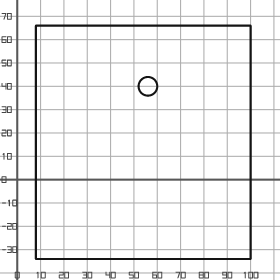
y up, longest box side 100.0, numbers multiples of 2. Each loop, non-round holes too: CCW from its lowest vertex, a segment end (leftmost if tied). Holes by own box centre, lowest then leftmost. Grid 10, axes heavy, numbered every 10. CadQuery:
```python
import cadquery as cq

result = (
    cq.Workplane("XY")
    .moveTo(8.0, -34.0)
    .lineTo(100.0, -34.0)
    .lineTo(100.0, 66.0)
    .lineTo(8.0, 66.0)
    .close()
    .moveTo(56.0, 40.0)
    .circle(4.0)
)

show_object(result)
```